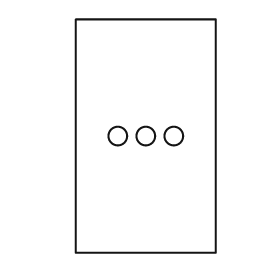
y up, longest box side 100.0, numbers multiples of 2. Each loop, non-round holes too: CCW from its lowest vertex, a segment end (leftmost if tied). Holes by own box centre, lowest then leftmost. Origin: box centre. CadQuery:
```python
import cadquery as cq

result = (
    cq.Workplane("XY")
    .moveTo(-30.0, -50.0)
    .lineTo(30.0, -50.0)
    .lineTo(30.0, 50.0)
    .lineTo(-30.0, 50.0)
    .close()
    .moveTo(-12.0, 0.0)
    .circle(4.0)
    .moveTo(0.0, 0.0)
    .circle(4.0)
    .moveTo(12.0, 0.0)
    .circle(4.0)
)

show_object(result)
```